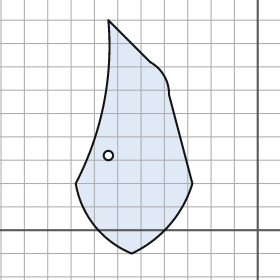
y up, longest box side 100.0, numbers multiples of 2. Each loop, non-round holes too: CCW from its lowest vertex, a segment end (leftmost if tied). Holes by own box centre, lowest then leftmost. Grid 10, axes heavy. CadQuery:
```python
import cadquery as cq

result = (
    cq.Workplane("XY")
    .moveTo(-54.0, -10.0)
    .threePointArc((-38.0, 2.0), (-28.0, 20.0))
    .lineTo(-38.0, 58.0)
    .threePointArc((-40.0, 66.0), (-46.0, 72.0))
    .lineTo(-64.0, 90.0)
    .threePointArc((-66.0, 54.0), (-78.0, 20.0))
    .threePointArc((-70.0, 2.0), (-54.0, -10.0))
    .close()
    .moveTo(-64.0, 32.0)
    .circle(2.0)
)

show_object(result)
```